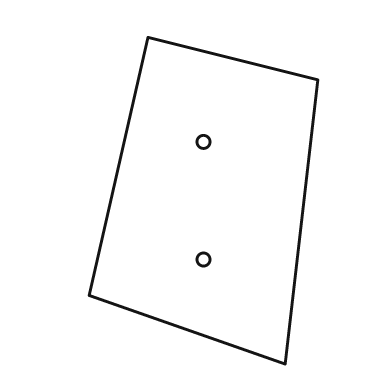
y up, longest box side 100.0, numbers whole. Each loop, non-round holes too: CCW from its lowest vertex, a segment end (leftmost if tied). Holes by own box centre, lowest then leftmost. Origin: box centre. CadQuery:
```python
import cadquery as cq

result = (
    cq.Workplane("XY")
    .moveTo(25.0, -50.0)
    .lineTo(35.0, 37.0)
    .lineTo(-17.0, 50.0)
    .lineTo(-35.0, -29.0)
    .close()
    .moveTo(0.0, -18.0)
    .circle(2.0)
    .moveTo(0.0, 18.0)
    .circle(2.0)
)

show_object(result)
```